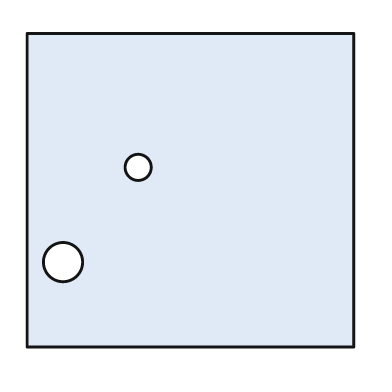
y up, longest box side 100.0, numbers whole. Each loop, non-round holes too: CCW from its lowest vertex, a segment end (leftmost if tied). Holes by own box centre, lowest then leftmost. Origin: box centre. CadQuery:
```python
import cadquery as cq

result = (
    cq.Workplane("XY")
    .moveTo(-50.0, -48.0)
    .lineTo(50.0, -48.0)
    .lineTo(50.0, 48.0)
    .lineTo(-50.0, 48.0)
    .close()
    .moveTo(-39.0, -22.0)
    .circle(6.0)
    .moveTo(-16.0, 7.0)
    .circle(4.0)
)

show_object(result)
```